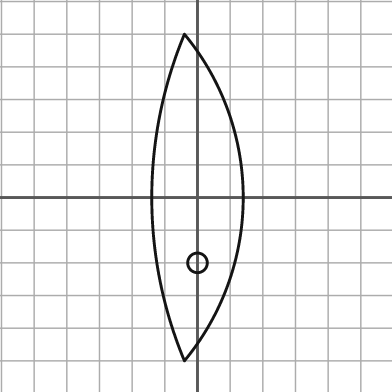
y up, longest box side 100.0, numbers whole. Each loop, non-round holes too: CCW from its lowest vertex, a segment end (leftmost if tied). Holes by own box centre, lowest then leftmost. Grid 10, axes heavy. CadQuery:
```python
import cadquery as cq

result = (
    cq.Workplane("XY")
    .moveTo(-4.0, -50.0)
    .threePointArc((14.0, 0.0), (-4.0, 50.0))
    .threePointArc((-14.0, 0.0), (-4.0, -50.0))
    .close()
    .moveTo(0.0, -20.0)
    .circle(3.0)
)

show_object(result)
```